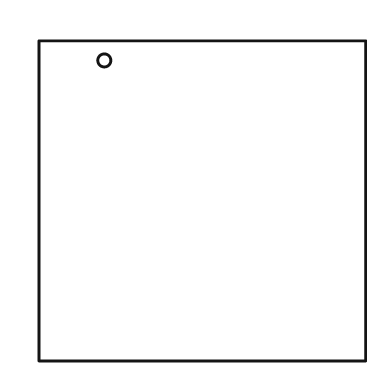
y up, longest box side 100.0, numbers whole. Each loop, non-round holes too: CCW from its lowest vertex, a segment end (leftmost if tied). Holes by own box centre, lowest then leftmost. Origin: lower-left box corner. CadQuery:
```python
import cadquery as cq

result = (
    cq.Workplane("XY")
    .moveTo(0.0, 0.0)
    .lineTo(100.0, 0.0)
    .lineTo(100.0, 98.0)
    .lineTo(0.0, 98.0)
    .close()
    .moveTo(20.0, 92.0)
    .circle(2.0)
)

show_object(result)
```